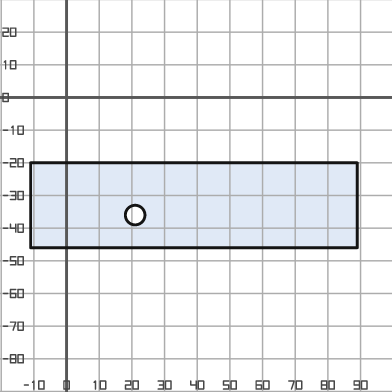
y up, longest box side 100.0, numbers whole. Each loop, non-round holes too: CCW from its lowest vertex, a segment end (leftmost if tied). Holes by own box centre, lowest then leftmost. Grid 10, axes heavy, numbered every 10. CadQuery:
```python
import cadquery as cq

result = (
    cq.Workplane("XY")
    .moveTo(-11.0, -46.0)
    .lineTo(89.0, -46.0)
    .lineTo(89.0, -20.0)
    .lineTo(-11.0, -20.0)
    .close()
    .moveTo(21.0, -36.0)
    .circle(3.0)
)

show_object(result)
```